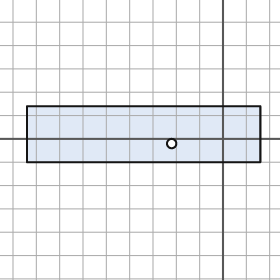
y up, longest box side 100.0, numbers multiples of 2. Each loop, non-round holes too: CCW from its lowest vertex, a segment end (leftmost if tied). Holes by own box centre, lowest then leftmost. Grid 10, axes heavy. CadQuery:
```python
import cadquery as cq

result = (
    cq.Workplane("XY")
    .moveTo(-84.0, -10.0)
    .lineTo(16.0, -10.0)
    .lineTo(16.0, 14.0)
    .lineTo(-84.0, 14.0)
    .close()
    .moveTo(-22.0, -2.0)
    .circle(2.0)
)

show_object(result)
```